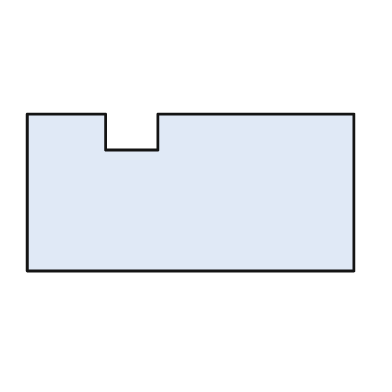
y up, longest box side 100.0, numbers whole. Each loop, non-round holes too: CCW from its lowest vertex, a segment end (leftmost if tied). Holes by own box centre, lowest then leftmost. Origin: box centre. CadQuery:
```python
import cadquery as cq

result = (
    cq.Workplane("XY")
    .moveTo(-50.0, -24.0)
    .lineTo(50.0, -24.0)
    .lineTo(50.0, 24.0)
    .lineTo(-10.0, 24.0)
    .lineTo(-10.0, 13.0)
    .lineTo(-26.0, 13.0)
    .lineTo(-26.0, 24.0)
    .lineTo(-50.0, 24.0)
    .close()
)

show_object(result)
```